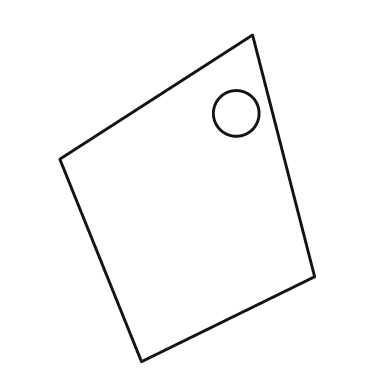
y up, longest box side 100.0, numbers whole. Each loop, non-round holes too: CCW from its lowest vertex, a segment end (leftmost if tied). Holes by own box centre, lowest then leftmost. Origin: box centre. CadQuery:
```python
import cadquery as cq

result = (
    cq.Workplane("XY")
    .moveTo(-14.0, -50.0)
    .lineTo(39.0, -24.0)
    .lineTo(20.0, 50.0)
    .lineTo(-39.0, 12.0)
    .close()
    .moveTo(15.0, 26.0)
    .circle(7.0)
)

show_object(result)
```